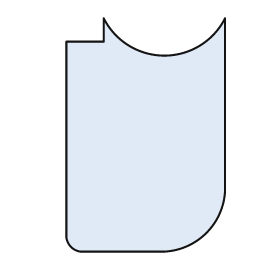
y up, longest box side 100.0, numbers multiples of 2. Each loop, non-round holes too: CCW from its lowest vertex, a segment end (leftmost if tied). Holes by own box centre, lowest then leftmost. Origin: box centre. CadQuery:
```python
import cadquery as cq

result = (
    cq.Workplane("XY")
    .moveTo(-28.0, -50.0)
    .lineTo(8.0, -50.0)
    .threePointArc((26.0, -42.0), (34.0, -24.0))
    .lineTo(34.0, 50.0)
    .threePointArc((8.0, 34.0), (-18.0, 50.0))
    .lineTo(-18.0, 40.0)
    .lineTo(-34.0, 40.0)
    .lineTo(-34.0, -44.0)
    .threePointArc((-32.0, -48.0), (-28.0, -50.0))
    .close()
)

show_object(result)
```